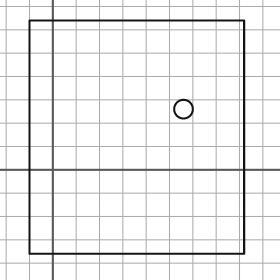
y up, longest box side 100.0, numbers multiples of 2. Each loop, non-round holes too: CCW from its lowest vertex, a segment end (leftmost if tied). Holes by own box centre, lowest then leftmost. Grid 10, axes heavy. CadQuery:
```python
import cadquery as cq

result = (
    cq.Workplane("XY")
    .moveTo(-10.0, -36.0)
    .lineTo(82.0, -36.0)
    .lineTo(82.0, 64.0)
    .lineTo(-10.0, 64.0)
    .close()
    .moveTo(56.0, 26.0)
    .circle(4.0)
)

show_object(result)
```